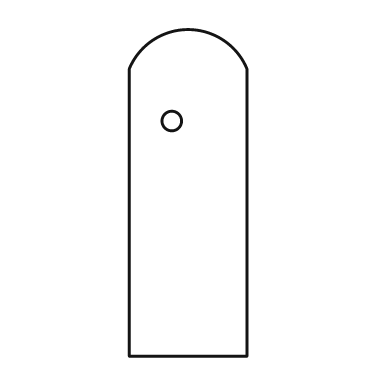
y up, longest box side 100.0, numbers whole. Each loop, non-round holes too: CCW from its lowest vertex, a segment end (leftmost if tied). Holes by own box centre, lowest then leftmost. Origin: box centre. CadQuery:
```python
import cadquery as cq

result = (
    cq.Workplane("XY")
    .moveTo(-18.0, -50.0)
    .lineTo(18.0, -50.0)
    .lineTo(18.0, 38.0)
    .threePointArc((0.0, 50.0), (-18.0, 38.0))
    .close()
    .moveTo(-5.0, 22.0)
    .circle(3.0)
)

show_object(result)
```